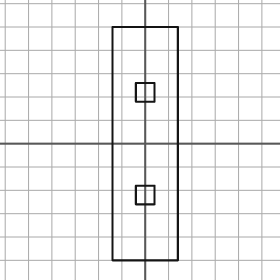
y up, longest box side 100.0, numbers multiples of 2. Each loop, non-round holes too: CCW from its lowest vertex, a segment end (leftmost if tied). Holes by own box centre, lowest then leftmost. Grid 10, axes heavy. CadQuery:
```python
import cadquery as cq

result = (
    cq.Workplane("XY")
    .moveTo(-14.0, -50.0)
    .lineTo(14.0, -50.0)
    .lineTo(14.0, 50.0)
    .lineTo(-14.0, 50.0)
    .close()
    .moveTo(-4.0, -26.0)
    .lineTo(4.0, -26.0)
    .lineTo(4.0, -18.0)
    .lineTo(-4.0, -18.0)
    .close()
    .moveTo(-4.0, 18.0)
    .lineTo(4.0, 18.0)
    .lineTo(4.0, 26.0)
    .lineTo(-4.0, 26.0)
    .close()
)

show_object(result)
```